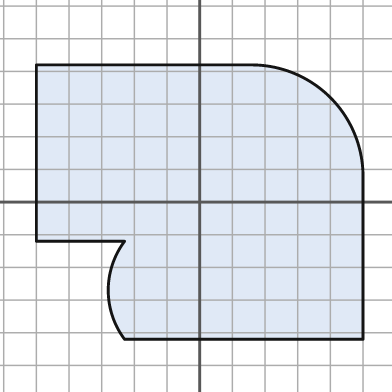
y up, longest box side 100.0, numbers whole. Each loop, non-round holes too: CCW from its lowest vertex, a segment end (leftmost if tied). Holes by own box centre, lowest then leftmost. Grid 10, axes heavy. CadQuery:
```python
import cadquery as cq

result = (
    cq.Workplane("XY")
    .moveTo(-23.0, -42.0)
    .lineTo(50.0, -42.0)
    .lineTo(50.0, 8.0)
    .threePointArc((40.0, 32.0), (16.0, 42.0))
    .lineTo(-50.0, 42.0)
    .lineTo(-50.0, -12.0)
    .lineTo(-23.0, -12.0)
    .threePointArc((-28.0, -27.0), (-23.0, -42.0))
    .close()
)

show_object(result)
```